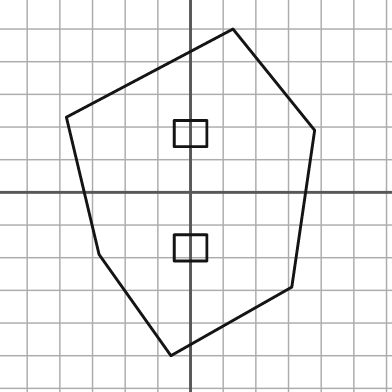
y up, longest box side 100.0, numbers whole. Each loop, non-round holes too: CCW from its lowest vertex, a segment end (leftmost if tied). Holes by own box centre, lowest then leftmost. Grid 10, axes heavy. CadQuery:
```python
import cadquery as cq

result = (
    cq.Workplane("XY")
    .moveTo(-6.0, -50.0)
    .lineTo(31.0, -29.0)
    .lineTo(38.0, 19.0)
    .lineTo(13.0, 50.0)
    .lineTo(-38.0, 23.0)
    .lineTo(-28.0, -19.0)
    .close()
    .moveTo(-5.0, -21.0)
    .lineTo(5.0, -21.0)
    .lineTo(5.0, -13.0)
    .lineTo(-5.0, -13.0)
    .close()
    .moveTo(-5.0, 14.0)
    .lineTo(5.0, 14.0)
    .lineTo(5.0, 22.0)
    .lineTo(-5.0, 22.0)
    .close()
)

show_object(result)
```